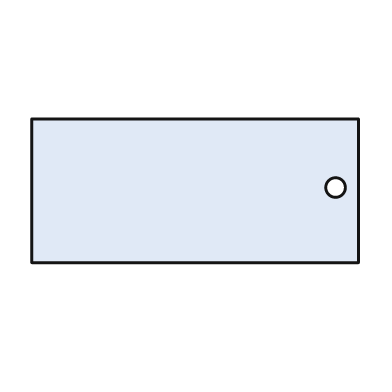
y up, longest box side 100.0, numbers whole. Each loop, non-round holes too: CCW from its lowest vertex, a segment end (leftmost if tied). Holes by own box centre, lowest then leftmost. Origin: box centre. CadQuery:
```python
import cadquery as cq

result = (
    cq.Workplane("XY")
    .moveTo(-50.0, -22.0)
    .lineTo(50.0, -22.0)
    .lineTo(50.0, 22.0)
    .lineTo(-50.0, 22.0)
    .close()
    .moveTo(43.0, 1.0)
    .circle(3.0)
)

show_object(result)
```